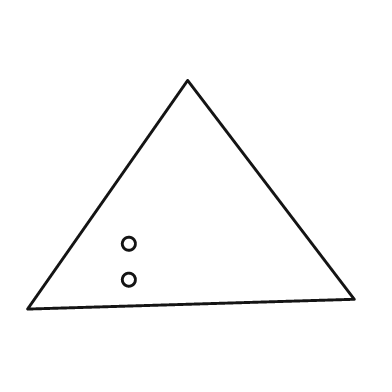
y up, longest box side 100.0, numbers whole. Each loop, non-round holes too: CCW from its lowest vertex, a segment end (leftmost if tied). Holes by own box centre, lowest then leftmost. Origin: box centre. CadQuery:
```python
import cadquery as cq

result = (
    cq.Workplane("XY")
    .moveTo(-50.0, -35.0)
    .lineTo(50.0, -32.0)
    .lineTo(-1.0, 35.0)
    .close()
    .moveTo(-19.0, -26.0)
    .circle(2.0)
    .moveTo(-19.0, -15.0)
    .circle(2.0)
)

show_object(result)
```